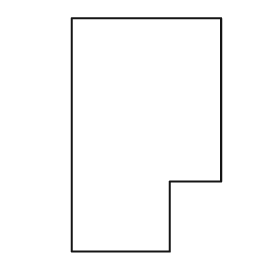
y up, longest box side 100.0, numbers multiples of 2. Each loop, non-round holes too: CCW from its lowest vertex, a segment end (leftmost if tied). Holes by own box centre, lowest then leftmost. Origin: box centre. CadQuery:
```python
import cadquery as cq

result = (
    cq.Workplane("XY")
    .moveTo(-32.0, -50.0)
    .lineTo(10.0, -50.0)
    .lineTo(10.0, -20.0)
    .lineTo(32.0, -20.0)
    .lineTo(32.0, 50.0)
    .lineTo(-32.0, 50.0)
    .close()
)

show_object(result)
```